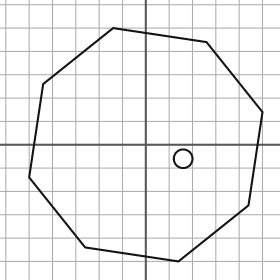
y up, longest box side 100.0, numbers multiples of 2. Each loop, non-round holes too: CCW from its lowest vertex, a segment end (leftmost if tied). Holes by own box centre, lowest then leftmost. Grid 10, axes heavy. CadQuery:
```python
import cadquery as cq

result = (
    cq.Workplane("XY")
    .moveTo(14.0, -50.0)
    .lineTo(44.0, -26.0)
    .lineTo(50.0, 14.0)
    .lineTo(26.0, 44.0)
    .lineTo(-14.0, 50.0)
    .lineTo(-44.0, 26.0)
    .lineTo(-50.0, -14.0)
    .lineTo(-26.0, -44.0)
    .close()
    .moveTo(16.0, -6.0)
    .circle(4.0)
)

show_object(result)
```